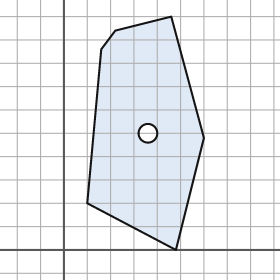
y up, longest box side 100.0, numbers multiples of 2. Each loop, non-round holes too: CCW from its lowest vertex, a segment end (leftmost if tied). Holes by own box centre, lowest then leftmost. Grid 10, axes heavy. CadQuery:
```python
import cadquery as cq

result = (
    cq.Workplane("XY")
    .moveTo(48.0, 0.0)
    .lineTo(60.0, 48.0)
    .lineTo(46.0, 100.0)
    .lineTo(22.0, 94.0)
    .lineTo(16.0, 86.0)
    .lineTo(10.0, 20.0)
    .close()
    .moveTo(36.0, 50.0)
    .circle(4.0)
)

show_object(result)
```